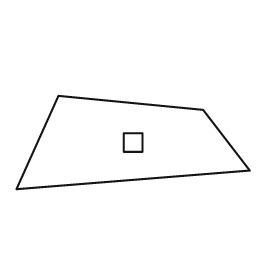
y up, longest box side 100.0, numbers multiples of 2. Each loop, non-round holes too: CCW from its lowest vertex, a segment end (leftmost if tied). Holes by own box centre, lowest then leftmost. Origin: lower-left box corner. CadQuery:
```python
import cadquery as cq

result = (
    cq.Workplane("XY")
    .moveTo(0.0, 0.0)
    .lineTo(100.0, 8.0)
    .lineTo(80.0, 34.0)
    .lineTo(18.0, 40.0)
    .close()
    .moveTo(46.0, 16.0)
    .lineTo(54.0, 16.0)
    .lineTo(54.0, 24.0)
    .lineTo(46.0, 24.0)
    .close()
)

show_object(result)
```